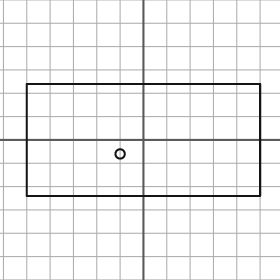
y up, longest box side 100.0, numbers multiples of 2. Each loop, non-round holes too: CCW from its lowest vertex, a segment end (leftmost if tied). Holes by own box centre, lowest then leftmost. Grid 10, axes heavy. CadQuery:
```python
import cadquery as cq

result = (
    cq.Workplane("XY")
    .moveTo(-50.0, -24.0)
    .lineTo(50.0, -24.0)
    .lineTo(50.0, 24.0)
    .lineTo(-50.0, 24.0)
    .close()
    .moveTo(-10.0, -6.0)
    .circle(2.0)
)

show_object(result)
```